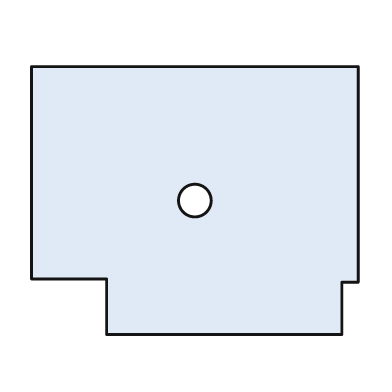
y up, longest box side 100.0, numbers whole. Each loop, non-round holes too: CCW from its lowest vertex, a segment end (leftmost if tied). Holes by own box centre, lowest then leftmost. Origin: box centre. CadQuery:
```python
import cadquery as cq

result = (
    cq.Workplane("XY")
    .moveTo(-27.0, -41.0)
    .lineTo(45.0, -41.0)
    .lineTo(45.0, -25.0)
    .lineTo(50.0, -25.0)
    .lineTo(50.0, 41.0)
    .lineTo(-50.0, 41.0)
    .lineTo(-50.0, -24.0)
    .lineTo(-27.0, -24.0)
    .close()
    .moveTo(0.0, 0.0)
    .circle(5.0)
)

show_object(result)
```